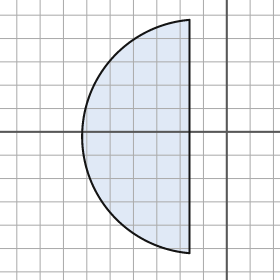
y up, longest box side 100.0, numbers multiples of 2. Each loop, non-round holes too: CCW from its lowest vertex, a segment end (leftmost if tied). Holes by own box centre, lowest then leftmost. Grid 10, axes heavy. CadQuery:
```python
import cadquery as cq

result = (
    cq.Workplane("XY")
    .moveTo(-16.0, -52.0)
    .lineTo(-16.0, 48.0)
    .threePointArc((-62.0, -2.0), (-16.0, -52.0))
    .close()
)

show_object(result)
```